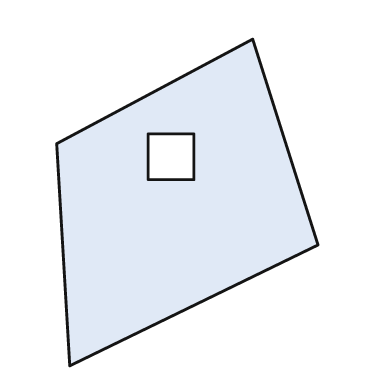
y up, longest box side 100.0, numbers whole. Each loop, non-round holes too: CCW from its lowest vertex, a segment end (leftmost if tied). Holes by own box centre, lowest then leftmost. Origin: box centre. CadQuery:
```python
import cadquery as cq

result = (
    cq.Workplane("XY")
    .moveTo(-36.0, -50.0)
    .lineTo(40.0, -13.0)
    .lineTo(20.0, 50.0)
    .lineTo(-40.0, 18.0)
    .close()
    .moveTo(-12.0, 7.0)
    .lineTo(2.0, 7.0)
    .lineTo(2.0, 21.0)
    .lineTo(-12.0, 21.0)
    .close()
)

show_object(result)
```